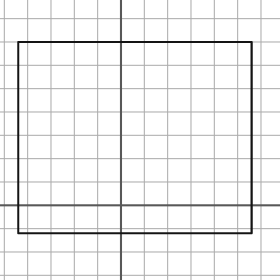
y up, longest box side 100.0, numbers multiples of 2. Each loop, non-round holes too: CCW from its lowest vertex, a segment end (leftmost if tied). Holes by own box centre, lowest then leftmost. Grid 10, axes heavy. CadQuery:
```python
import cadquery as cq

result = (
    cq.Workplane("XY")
    .moveTo(-44.0, -12.0)
    .lineTo(56.0, -12.0)
    .lineTo(56.0, 70.0)
    .lineTo(-44.0, 70.0)
    .close()
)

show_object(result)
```